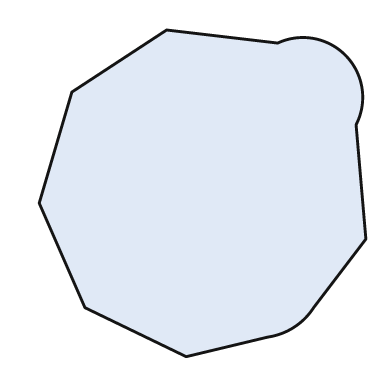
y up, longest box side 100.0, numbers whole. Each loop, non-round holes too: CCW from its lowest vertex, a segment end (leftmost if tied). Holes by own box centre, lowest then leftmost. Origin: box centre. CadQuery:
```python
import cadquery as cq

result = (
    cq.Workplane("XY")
    .moveTo(-5.0, -50.0)
    .lineTo(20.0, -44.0)
    .threePointArc((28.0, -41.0), (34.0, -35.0))
    .lineTo(50.0, -14.0)
    .lineTo(47.0, 21.0)
    .threePointArc((44.0, 42.0), (23.0, 46.0))
    .lineTo(-11.0, 50.0)
    .lineTo(-40.0, 31.0)
    .lineTo(-50.0, -3.0)
    .lineTo(-36.0, -35.0)
    .close()
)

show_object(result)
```